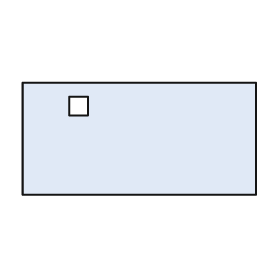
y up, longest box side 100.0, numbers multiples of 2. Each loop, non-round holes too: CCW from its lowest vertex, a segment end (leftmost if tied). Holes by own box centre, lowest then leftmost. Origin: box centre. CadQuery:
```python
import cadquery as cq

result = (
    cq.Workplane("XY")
    .moveTo(-50.0, -24.0)
    .lineTo(50.0, -24.0)
    .lineTo(50.0, 24.0)
    .lineTo(-50.0, 24.0)
    .close()
    .moveTo(-30.0, 10.0)
    .lineTo(-22.0, 10.0)
    .lineTo(-22.0, 18.0)
    .lineTo(-30.0, 18.0)
    .close()
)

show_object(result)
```